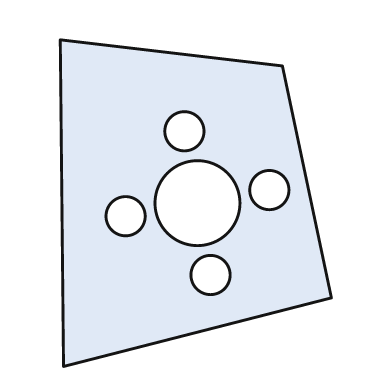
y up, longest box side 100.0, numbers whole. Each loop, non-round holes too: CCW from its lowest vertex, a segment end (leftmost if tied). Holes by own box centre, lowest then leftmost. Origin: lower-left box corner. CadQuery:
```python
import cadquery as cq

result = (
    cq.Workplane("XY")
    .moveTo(1.0, 0.0)
    .lineTo(83.0, 21.0)
    .lineTo(68.0, 92.0)
    .lineTo(0.0, 100.0)
    .close()
    .moveTo(46.0, 28.0)
    .circle(6.0)
    .moveTo(20.0, 46.0)
    .circle(6.0)
    .moveTo(42.0, 50.0)
    .circle(13.0)
    .moveTo(64.0, 54.0)
    .circle(6.0)
    .moveTo(38.0, 72.0)
    .circle(6.0)
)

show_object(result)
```